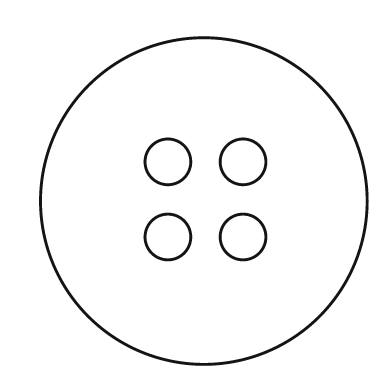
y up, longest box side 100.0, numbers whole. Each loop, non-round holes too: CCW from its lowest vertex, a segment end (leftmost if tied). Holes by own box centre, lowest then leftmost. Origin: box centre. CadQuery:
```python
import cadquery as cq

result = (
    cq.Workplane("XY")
    .moveTo(0.0, 0.0)
    .circle(50.0)
    .moveTo(-11.0, -11.0)
    .circle(7.0)
    .moveTo(12.0, -11.0)
    .circle(7.0)
    .moveTo(-11.0, 12.0)
    .circle(7.0)
    .moveTo(12.0, 12.0)
    .circle(7.0)
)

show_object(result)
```